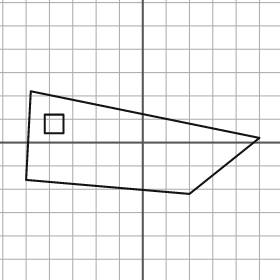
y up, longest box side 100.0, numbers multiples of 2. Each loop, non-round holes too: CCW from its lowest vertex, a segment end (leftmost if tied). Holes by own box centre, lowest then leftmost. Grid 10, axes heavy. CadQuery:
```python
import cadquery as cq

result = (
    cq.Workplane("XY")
    .moveTo(20.0, -22.0)
    .lineTo(50.0, 2.0)
    .lineTo(-48.0, 22.0)
    .lineTo(-50.0, -16.0)
    .close()
    .moveTo(-42.0, 4.0)
    .lineTo(-34.0, 4.0)
    .lineTo(-34.0, 12.0)
    .lineTo(-42.0, 12.0)
    .close()
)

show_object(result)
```